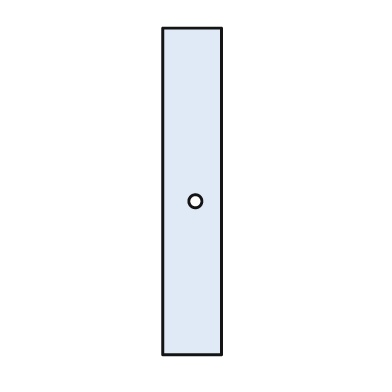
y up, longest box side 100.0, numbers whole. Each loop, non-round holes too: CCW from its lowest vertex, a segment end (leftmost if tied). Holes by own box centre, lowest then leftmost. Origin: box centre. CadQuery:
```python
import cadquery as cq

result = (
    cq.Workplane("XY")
    .moveTo(-9.0, -50.0)
    .lineTo(9.0, -50.0)
    .lineTo(9.0, 50.0)
    .lineTo(-9.0, 50.0)
    .close()
    .moveTo(1.0, -3.0)
    .circle(2.0)
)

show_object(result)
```